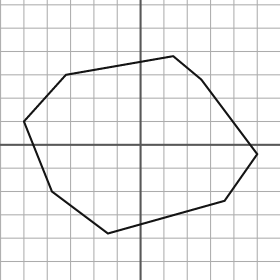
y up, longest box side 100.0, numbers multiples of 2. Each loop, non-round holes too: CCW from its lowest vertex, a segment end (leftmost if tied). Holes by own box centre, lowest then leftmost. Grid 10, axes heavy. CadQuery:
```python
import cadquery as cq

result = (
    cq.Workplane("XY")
    .moveTo(-14.0, -38.0)
    .lineTo(36.0, -24.0)
    .lineTo(50.0, -4.0)
    .lineTo(26.0, 28.0)
    .lineTo(14.0, 38.0)
    .lineTo(-32.0, 30.0)
    .lineTo(-50.0, 10.0)
    .lineTo(-38.0, -20.0)
    .close()
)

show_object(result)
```